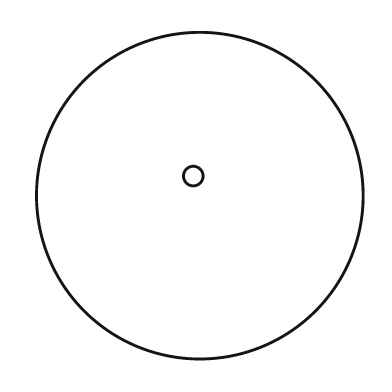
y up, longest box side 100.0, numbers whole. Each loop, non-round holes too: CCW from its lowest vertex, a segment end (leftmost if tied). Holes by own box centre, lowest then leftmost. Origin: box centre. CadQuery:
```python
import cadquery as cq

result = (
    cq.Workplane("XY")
    .moveTo(0.0, 0.0)
    .circle(50.0)
    .moveTo(-2.0, 6.0)
    .circle(3.0)
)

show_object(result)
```